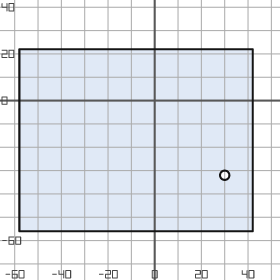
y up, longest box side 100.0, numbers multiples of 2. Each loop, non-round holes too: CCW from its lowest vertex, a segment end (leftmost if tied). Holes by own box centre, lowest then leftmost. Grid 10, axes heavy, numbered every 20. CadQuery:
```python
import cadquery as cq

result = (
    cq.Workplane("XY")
    .moveTo(-58.0, -56.0)
    .lineTo(42.0, -56.0)
    .lineTo(42.0, 22.0)
    .lineTo(-58.0, 22.0)
    .close()
    .moveTo(30.0, -32.0)
    .circle(2.0)
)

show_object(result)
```